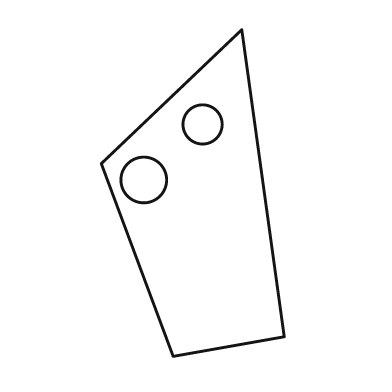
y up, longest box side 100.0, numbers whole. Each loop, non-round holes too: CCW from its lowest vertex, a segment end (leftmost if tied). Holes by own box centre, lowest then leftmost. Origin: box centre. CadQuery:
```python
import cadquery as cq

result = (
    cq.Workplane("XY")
    .moveTo(-6.0, -50.0)
    .lineTo(28.0, -44.0)
    .lineTo(15.0, 50.0)
    .lineTo(-28.0, 9.0)
    .close()
    .moveTo(-15.0, 4.0)
    .circle(7.0)
    .moveTo(3.0, 21.0)
    .circle(6.0)
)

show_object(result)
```